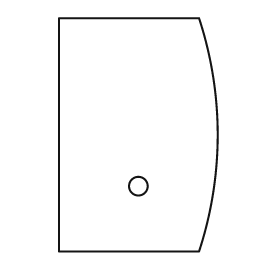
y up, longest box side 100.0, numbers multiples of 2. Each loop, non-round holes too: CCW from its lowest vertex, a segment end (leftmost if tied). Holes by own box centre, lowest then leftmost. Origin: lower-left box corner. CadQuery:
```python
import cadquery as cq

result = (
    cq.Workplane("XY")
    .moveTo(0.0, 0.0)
    .lineTo(60.0, 0.0)
    .threePointArc((68.0, 50.0), (60.0, 100.0))
    .lineTo(0.0, 100.0)
    .close()
    .moveTo(34.0, 28.0)
    .circle(4.0)
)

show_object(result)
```